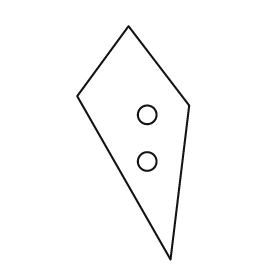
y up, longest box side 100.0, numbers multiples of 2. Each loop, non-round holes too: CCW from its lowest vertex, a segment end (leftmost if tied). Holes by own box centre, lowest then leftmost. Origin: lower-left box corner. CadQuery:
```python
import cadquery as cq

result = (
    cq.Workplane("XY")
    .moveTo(40.0, 0.0)
    .lineTo(48.0, 66.0)
    .lineTo(22.0, 100.0)
    .lineTo(0.0, 70.0)
    .close()
    .moveTo(30.0, 42.0)
    .circle(4.0)
    .moveTo(30.0, 62.0)
    .circle(4.0)
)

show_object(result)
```